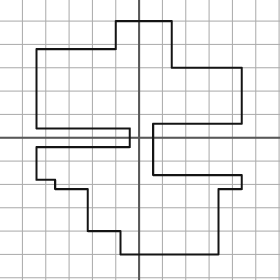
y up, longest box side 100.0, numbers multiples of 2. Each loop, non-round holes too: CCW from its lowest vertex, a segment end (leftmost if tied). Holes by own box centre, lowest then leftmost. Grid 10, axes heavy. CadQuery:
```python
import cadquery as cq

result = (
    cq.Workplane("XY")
    .moveTo(-8.0, -50.0)
    .lineTo(34.0, -50.0)
    .lineTo(34.0, -22.0)
    .lineTo(44.0, -22.0)
    .lineTo(44.0, -16.0)
    .lineTo(6.0, -16.0)
    .lineTo(6.0, 6.0)
    .lineTo(44.0, 6.0)
    .lineTo(44.0, 30.0)
    .lineTo(14.0, 30.0)
    .lineTo(14.0, 50.0)
    .lineTo(-10.0, 50.0)
    .lineTo(-10.0, 38.0)
    .lineTo(-44.0, 38.0)
    .lineTo(-44.0, 4.0)
    .lineTo(-4.0, 4.0)
    .lineTo(-4.0, -4.0)
    .lineTo(-44.0, -4.0)
    .lineTo(-44.0, -18.0)
    .lineTo(-36.0, -18.0)
    .lineTo(-36.0, -22.0)
    .lineTo(-22.0, -22.0)
    .lineTo(-22.0, -40.0)
    .lineTo(-8.0, -40.0)
    .close()
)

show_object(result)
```